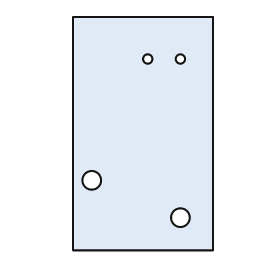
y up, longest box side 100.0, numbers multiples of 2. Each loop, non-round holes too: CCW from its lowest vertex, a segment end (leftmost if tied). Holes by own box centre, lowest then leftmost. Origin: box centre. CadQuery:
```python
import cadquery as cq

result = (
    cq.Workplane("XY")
    .moveTo(-30.0, -50.0)
    .lineTo(30.0, -50.0)
    .lineTo(30.0, 50.0)
    .lineTo(-30.0, 50.0)
    .close()
    .moveTo(16.0, -36.0)
    .circle(4.0)
    .moveTo(-22.0, -20.0)
    .circle(4.0)
    .moveTo(2.0, 32.0)
    .circle(2.0)
    .moveTo(16.0, 32.0)
    .circle(2.0)
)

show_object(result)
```